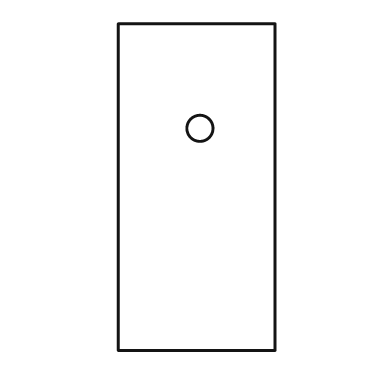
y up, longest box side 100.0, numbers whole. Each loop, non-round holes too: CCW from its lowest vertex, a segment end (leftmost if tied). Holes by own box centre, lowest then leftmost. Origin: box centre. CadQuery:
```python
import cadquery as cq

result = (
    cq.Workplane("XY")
    .moveTo(-24.0, -50.0)
    .lineTo(24.0, -50.0)
    .lineTo(24.0, 50.0)
    .lineTo(-24.0, 50.0)
    .close()
    .moveTo(1.0, 18.0)
    .circle(4.0)
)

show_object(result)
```